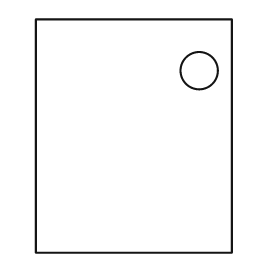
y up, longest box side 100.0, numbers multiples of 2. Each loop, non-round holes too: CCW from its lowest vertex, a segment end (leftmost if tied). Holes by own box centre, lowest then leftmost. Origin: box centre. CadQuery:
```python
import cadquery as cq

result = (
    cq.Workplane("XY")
    .moveTo(-42.0, -50.0)
    .lineTo(42.0, -50.0)
    .lineTo(42.0, 50.0)
    .lineTo(-42.0, 50.0)
    .close()
    .moveTo(28.0, 28.0)
    .circle(8.0)
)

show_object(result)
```